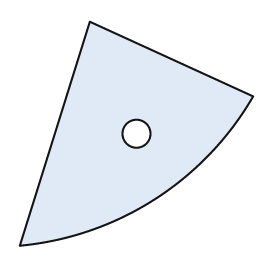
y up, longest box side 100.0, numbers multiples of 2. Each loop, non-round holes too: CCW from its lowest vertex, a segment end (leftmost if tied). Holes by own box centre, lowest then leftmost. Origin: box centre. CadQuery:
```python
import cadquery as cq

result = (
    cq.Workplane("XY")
    .moveTo(-50.0, -48.0)
    .threePointArc((8.0, -28.0), (50.0, 16.0))
    .lineTo(-20.0, 48.0)
    .close()
    .moveTo(0.0, 0.0)
    .circle(6.0)
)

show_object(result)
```